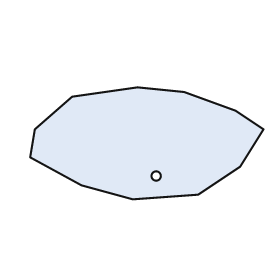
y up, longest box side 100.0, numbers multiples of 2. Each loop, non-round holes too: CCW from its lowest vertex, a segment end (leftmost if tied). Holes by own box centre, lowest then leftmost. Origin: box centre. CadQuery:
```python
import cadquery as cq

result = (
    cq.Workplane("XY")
    .moveTo(-6.0, -24.0)
    .lineTo(22.0, -22.0)
    .lineTo(40.0, -10.0)
    .lineTo(50.0, 6.0)
    .lineTo(38.0, 14.0)
    .lineTo(16.0, 22.0)
    .lineTo(-4.0, 24.0)
    .lineTo(-32.0, 20.0)
    .lineTo(-48.0, 6.0)
    .lineTo(-50.0, -6.0)
    .lineTo(-28.0, -18.0)
    .close()
    .moveTo(4.0, -14.0)
    .circle(2.0)
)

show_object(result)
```